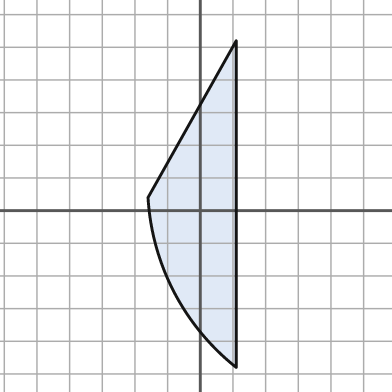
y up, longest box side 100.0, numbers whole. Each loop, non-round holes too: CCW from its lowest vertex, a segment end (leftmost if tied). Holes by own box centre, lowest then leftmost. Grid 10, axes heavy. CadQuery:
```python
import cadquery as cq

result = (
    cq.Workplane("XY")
    .moveTo(11.0, -48.0)
    .lineTo(11.0, 52.0)
    .lineTo(-16.0, 4.0)
    .threePointArc((-8.0, -25.0), (11.0, -48.0))
    .close()
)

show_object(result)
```